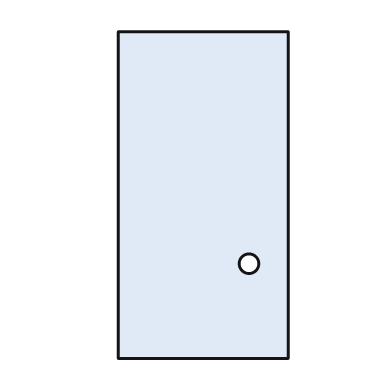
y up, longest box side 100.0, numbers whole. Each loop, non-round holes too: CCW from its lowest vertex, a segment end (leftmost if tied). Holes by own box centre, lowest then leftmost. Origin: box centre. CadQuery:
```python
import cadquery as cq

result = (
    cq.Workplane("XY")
    .moveTo(-26.0, -50.0)
    .lineTo(26.0, -50.0)
    .lineTo(26.0, 50.0)
    .lineTo(-26.0, 50.0)
    .close()
    .moveTo(14.0, -21.0)
    .circle(3.0)
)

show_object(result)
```